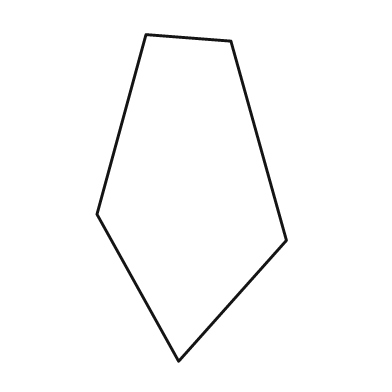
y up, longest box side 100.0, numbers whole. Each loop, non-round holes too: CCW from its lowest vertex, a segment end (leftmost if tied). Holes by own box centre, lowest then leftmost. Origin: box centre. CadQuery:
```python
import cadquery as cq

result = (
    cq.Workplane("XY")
    .moveTo(-4.0, -50.0)
    .lineTo(29.0, -13.0)
    .lineTo(12.0, 48.0)
    .lineTo(-14.0, 50.0)
    .lineTo(-29.0, -5.0)
    .close()
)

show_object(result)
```